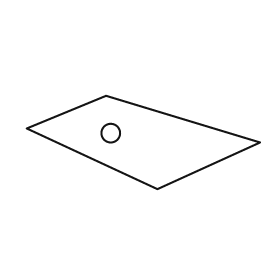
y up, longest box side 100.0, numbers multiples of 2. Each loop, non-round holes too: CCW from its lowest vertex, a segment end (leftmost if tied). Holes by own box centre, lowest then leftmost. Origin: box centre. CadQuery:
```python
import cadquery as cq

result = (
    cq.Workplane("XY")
    .moveTo(6.0, -20.0)
    .lineTo(50.0, 0.0)
    .lineTo(-16.0, 20.0)
    .lineTo(-50.0, 6.0)
    .close()
    .moveTo(-14.0, 4.0)
    .circle(4.0)
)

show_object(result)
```